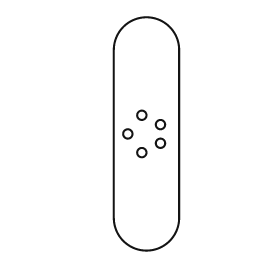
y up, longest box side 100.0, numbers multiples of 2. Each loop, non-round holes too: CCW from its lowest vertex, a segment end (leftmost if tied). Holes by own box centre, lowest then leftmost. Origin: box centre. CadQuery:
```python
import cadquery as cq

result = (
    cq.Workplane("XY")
    .moveTo(-14.0, -36.0)
    .threePointArc((0.0, -50.0), (14.0, -36.0))
    .lineTo(14.0, 36.0)
    .threePointArc((0.0, 50.0), (-14.0, 36.0))
    .close()
    .moveTo(-2.0, -8.0)
    .circle(2.0)
    .moveTo(6.0, -4.0)
    .circle(2.0)
    .moveTo(-8.0, 0.0)
    .circle(2.0)
    .moveTo(6.0, 4.0)
    .circle(2.0)
    .moveTo(-2.0, 8.0)
    .circle(2.0)
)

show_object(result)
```